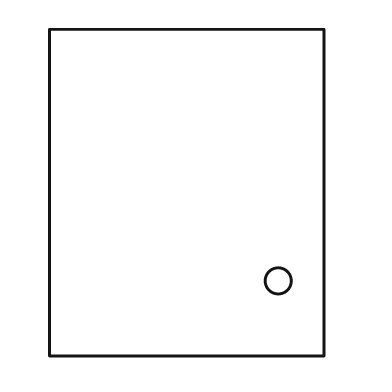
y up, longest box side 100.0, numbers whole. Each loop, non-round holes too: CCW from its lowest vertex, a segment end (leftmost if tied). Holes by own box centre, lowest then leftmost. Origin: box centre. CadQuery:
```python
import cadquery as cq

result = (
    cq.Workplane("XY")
    .moveTo(-42.0, -50.0)
    .lineTo(42.0, -50.0)
    .lineTo(42.0, 50.0)
    .lineTo(-42.0, 50.0)
    .close()
    .moveTo(28.0, -27.0)
    .circle(4.0)
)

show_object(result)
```